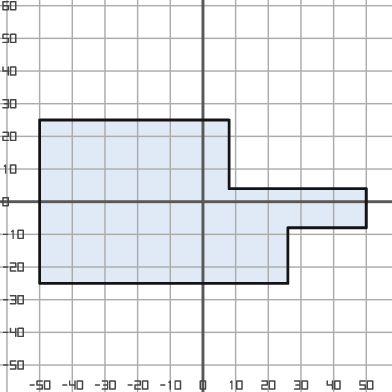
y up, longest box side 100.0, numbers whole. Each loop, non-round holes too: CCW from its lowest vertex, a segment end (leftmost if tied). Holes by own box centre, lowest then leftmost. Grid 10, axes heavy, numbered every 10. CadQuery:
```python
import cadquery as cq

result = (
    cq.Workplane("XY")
    .moveTo(-50.0, -25.0)
    .lineTo(26.0, -25.0)
    .lineTo(26.0, -8.0)
    .lineTo(50.0, -8.0)
    .lineTo(50.0, 4.0)
    .lineTo(8.0, 4.0)
    .lineTo(8.0, 25.0)
    .lineTo(-50.0, 25.0)
    .close()
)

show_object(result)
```